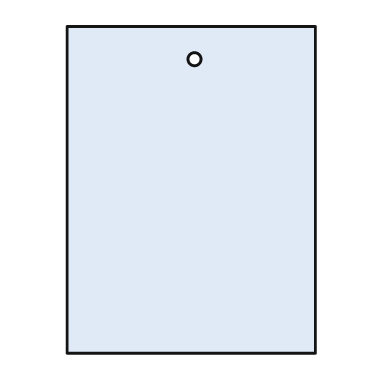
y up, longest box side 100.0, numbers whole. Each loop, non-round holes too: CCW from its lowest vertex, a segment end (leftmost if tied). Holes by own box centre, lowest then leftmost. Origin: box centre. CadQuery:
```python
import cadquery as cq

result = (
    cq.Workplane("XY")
    .moveTo(-38.0, -50.0)
    .lineTo(38.0, -50.0)
    .lineTo(38.0, 50.0)
    .lineTo(-38.0, 50.0)
    .close()
    .moveTo(1.0, 40.0)
    .circle(2.0)
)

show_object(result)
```